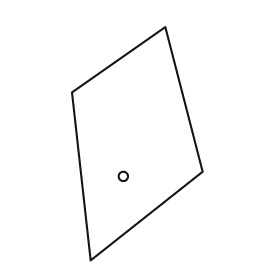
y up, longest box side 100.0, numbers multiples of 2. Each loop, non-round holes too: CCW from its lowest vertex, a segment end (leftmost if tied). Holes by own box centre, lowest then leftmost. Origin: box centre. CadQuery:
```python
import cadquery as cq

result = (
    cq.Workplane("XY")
    .moveTo(-20.0, -50.0)
    .lineTo(28.0, -12.0)
    .lineTo(12.0, 50.0)
    .lineTo(-28.0, 22.0)
    .close()
    .moveTo(-6.0, -14.0)
    .circle(2.0)
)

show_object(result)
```